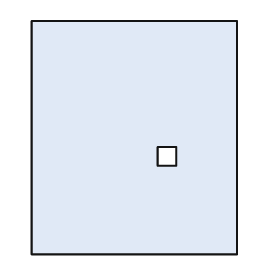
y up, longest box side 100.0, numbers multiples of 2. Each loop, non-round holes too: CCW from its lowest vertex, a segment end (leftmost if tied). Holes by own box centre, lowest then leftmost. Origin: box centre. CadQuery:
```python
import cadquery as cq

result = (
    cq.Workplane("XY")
    .moveTo(-44.0, -50.0)
    .lineTo(44.0, -50.0)
    .lineTo(44.0, 50.0)
    .lineTo(-44.0, 50.0)
    .close()
    .moveTo(10.0, -12.0)
    .lineTo(18.0, -12.0)
    .lineTo(18.0, -4.0)
    .lineTo(10.0, -4.0)
    .close()
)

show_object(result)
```